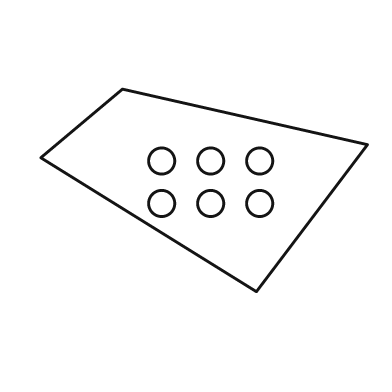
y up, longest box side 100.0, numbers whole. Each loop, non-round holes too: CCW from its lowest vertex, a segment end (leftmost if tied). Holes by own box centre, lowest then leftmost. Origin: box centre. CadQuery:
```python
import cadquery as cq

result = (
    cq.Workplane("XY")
    .moveTo(16.0, -31.0)
    .lineTo(50.0, 14.0)
    .lineTo(-25.0, 31.0)
    .lineTo(-50.0, 10.0)
    .close()
    .moveTo(-13.0, -4.0)
    .circle(4.0)
    .moveTo(2.0, -4.0)
    .circle(4.0)
    .moveTo(17.0, -4.0)
    .circle(4.0)
    .moveTo(-13.0, 9.0)
    .circle(4.0)
    .moveTo(2.0, 9.0)
    .circle(4.0)
    .moveTo(17.0, 9.0)
    .circle(4.0)
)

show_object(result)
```